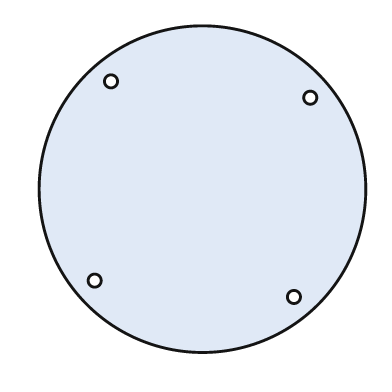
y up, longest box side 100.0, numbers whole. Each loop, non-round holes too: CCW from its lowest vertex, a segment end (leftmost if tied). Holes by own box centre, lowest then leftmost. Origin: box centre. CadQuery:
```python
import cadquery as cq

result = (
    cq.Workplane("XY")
    .moveTo(0.0, 0.0)
    .circle(50.0)
    .moveTo(28.0, -33.0)
    .circle(2.0)
    .moveTo(-33.0, -28.0)
    .circle(2.0)
    .moveTo(33.0, 28.0)
    .circle(2.0)
    .moveTo(-28.0, 33.0)
    .circle(2.0)
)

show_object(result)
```